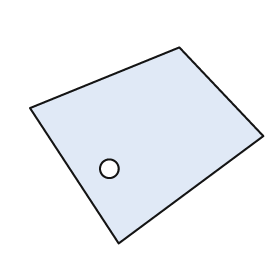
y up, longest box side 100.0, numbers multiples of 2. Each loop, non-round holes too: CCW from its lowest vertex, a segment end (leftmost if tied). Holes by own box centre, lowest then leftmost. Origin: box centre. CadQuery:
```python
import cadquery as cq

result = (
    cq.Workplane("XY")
    .moveTo(-12.0, -42.0)
    .lineTo(50.0, 4.0)
    .lineTo(14.0, 42.0)
    .lineTo(-50.0, 16.0)
    .close()
    .moveTo(-16.0, -10.0)
    .circle(4.0)
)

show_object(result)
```